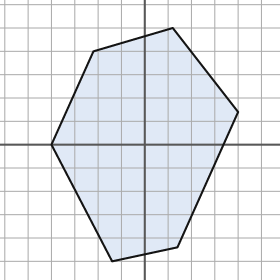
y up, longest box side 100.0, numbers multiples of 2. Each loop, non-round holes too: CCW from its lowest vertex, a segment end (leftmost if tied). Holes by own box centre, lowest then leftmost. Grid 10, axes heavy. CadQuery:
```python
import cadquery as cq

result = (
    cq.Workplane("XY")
    .moveTo(-14.0, -50.0)
    .lineTo(14.0, -44.0)
    .lineTo(40.0, 14.0)
    .lineTo(12.0, 50.0)
    .lineTo(-22.0, 40.0)
    .lineTo(-40.0, 0.0)
    .close()
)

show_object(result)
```